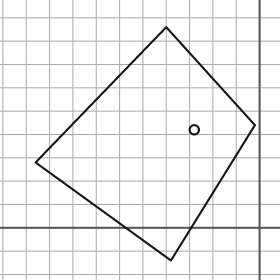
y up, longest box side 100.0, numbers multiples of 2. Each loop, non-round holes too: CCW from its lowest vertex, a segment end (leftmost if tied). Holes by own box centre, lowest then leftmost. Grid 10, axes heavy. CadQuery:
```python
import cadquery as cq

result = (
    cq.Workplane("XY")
    .moveTo(-38.0, -14.0)
    .lineTo(-2.0, 44.0)
    .lineTo(-40.0, 86.0)
    .lineTo(-96.0, 28.0)
    .close()
    .moveTo(-28.0, 42.0)
    .circle(2.0)
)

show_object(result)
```